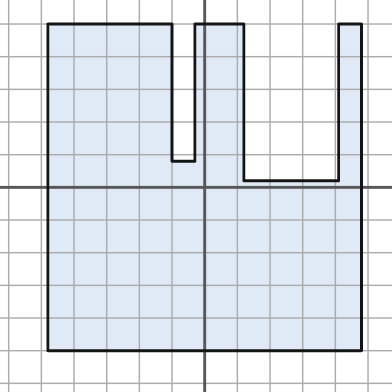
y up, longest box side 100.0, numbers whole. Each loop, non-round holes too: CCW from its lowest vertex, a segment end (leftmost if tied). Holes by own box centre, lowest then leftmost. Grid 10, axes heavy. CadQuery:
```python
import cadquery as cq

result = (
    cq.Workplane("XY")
    .moveTo(-48.0, -50.0)
    .lineTo(48.0, -50.0)
    .lineTo(48.0, 50.0)
    .lineTo(41.0, 50.0)
    .lineTo(41.0, 2.0)
    .lineTo(12.0, 2.0)
    .lineTo(12.0, 50.0)
    .lineTo(-3.0, 50.0)
    .lineTo(-3.0, 8.0)
    .lineTo(-10.0, 8.0)
    .lineTo(-10.0, 50.0)
    .lineTo(-48.0, 50.0)
    .close()
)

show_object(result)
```